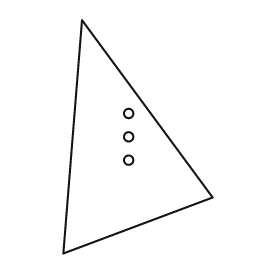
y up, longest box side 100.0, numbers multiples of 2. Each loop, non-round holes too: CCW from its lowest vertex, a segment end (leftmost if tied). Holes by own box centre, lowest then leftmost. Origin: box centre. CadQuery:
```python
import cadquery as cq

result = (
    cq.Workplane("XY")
    .moveTo(-32.0, -50.0)
    .lineTo(32.0, -26.0)
    .lineTo(-24.0, 50.0)
    .close()
    .moveTo(-4.0, -10.0)
    .circle(2.0)
    .moveTo(-4.0, 0.0)
    .circle(2.0)
    .moveTo(-4.0, 10.0)
    .circle(2.0)
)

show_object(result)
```